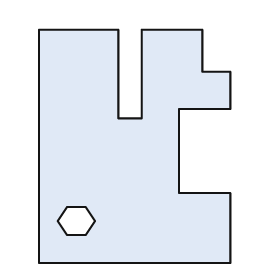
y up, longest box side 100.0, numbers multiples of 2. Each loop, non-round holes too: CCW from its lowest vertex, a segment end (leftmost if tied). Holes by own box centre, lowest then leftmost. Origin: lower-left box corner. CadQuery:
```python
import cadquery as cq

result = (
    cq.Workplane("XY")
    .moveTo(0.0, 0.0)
    .lineTo(82.0, 0.0)
    .lineTo(82.0, 30.0)
    .lineTo(60.0, 30.0)
    .lineTo(60.0, 66.0)
    .lineTo(82.0, 66.0)
    .lineTo(82.0, 82.0)
    .lineTo(70.0, 82.0)
    .lineTo(70.0, 100.0)
    .lineTo(44.0, 100.0)
    .lineTo(44.0, 62.0)
    .lineTo(34.0, 62.0)
    .lineTo(34.0, 100.0)
    .lineTo(0.0, 100.0)
    .close()
    .moveTo(12.0, 12.0)
    .lineTo(20.0, 12.0)
    .lineTo(24.0, 18.0)
    .lineTo(20.0, 24.0)
    .lineTo(12.0, 24.0)
    .lineTo(8.0, 18.0)
    .close()
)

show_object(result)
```